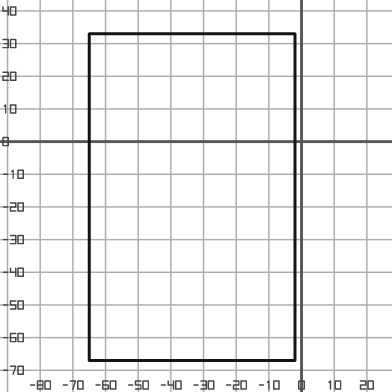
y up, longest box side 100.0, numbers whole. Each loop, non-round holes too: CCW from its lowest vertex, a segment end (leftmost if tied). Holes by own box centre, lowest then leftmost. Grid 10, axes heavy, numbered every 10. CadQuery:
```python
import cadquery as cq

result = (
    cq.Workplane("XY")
    .moveTo(-65.0, -67.0)
    .lineTo(-2.0, -67.0)
    .lineTo(-2.0, 33.0)
    .lineTo(-65.0, 33.0)
    .close()
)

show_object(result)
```